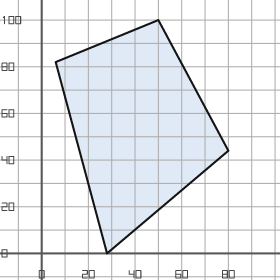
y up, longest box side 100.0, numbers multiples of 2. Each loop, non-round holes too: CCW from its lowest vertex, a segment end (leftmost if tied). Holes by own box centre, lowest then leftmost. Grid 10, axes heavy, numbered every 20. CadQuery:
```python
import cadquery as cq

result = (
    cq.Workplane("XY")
    .moveTo(28.0, 0.0)
    .lineTo(80.0, 44.0)
    .lineTo(50.0, 100.0)
    .lineTo(6.0, 82.0)
    .close()
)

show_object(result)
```